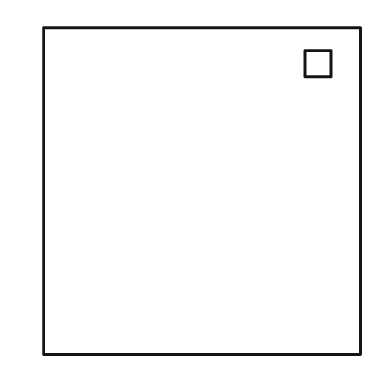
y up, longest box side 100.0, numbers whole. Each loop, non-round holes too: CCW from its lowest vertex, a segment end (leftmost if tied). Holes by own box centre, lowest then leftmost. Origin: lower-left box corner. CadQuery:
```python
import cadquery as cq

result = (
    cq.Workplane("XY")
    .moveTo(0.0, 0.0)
    .lineTo(97.0, 0.0)
    .lineTo(97.0, 100.0)
    .lineTo(0.0, 100.0)
    .close()
    .moveTo(80.0, 85.0)
    .lineTo(88.0, 85.0)
    .lineTo(88.0, 93.0)
    .lineTo(80.0, 93.0)
    .close()
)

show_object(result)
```